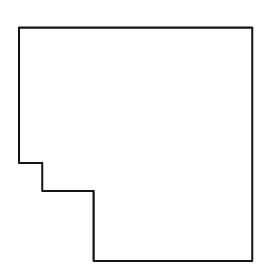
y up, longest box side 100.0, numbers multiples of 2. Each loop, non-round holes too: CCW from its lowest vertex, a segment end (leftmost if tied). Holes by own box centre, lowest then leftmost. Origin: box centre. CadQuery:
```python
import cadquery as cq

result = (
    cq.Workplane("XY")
    .moveTo(-18.0, -50.0)
    .lineTo(50.0, -50.0)
    .lineTo(50.0, 50.0)
    .lineTo(-50.0, 50.0)
    .lineTo(-50.0, -8.0)
    .lineTo(-40.0, -8.0)
    .lineTo(-40.0, -20.0)
    .lineTo(-18.0, -20.0)
    .close()
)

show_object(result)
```